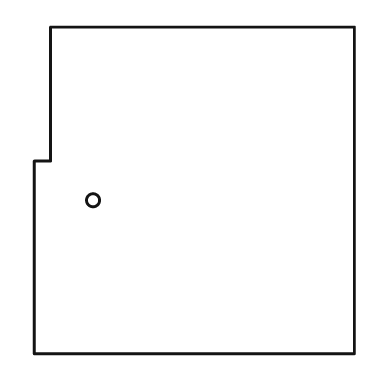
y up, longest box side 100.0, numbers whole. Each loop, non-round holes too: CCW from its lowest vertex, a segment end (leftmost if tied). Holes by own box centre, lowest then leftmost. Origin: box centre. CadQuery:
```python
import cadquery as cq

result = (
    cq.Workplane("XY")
    .moveTo(-49.0, -50.0)
    .lineTo(49.0, -50.0)
    .lineTo(49.0, 50.0)
    .lineTo(-44.0, 50.0)
    .lineTo(-44.0, 9.0)
    .lineTo(-49.0, 9.0)
    .close()
    .moveTo(-31.0, -3.0)
    .circle(2.0)
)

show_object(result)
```